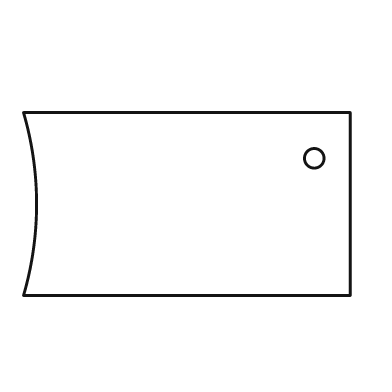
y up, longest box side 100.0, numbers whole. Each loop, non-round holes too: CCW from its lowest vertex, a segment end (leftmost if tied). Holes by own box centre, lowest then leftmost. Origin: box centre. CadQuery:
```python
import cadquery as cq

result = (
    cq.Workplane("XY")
    .moveTo(-50.0, -28.0)
    .lineTo(50.0, -28.0)
    .lineTo(50.0, 28.0)
    .lineTo(-50.0, 28.0)
    .threePointArc((-46.0, 0.0), (-50.0, -28.0))
    .close()
    .moveTo(39.0, 14.0)
    .circle(3.0)
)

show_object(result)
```